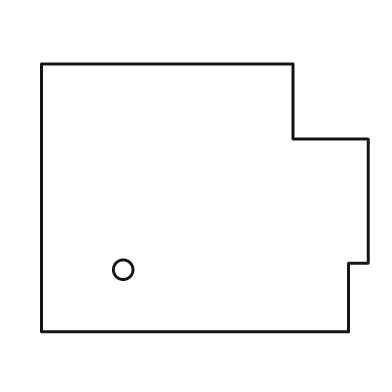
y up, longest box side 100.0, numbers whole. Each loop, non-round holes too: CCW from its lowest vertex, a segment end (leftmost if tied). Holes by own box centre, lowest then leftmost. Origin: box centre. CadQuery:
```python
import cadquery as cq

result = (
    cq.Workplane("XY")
    .moveTo(-50.0, -41.0)
    .lineTo(44.0, -41.0)
    .lineTo(44.0, -20.0)
    .lineTo(50.0, -20.0)
    .lineTo(50.0, 18.0)
    .lineTo(27.0, 18.0)
    .lineTo(27.0, 41.0)
    .lineTo(-50.0, 41.0)
    .close()
    .moveTo(-25.0, -22.0)
    .circle(3.0)
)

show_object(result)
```